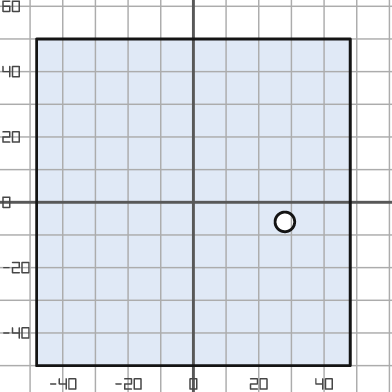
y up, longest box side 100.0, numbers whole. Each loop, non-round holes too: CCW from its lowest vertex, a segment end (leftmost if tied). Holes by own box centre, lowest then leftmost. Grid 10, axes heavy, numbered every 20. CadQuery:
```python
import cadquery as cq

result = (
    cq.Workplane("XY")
    .moveTo(-48.0, -50.0)
    .lineTo(48.0, -50.0)
    .lineTo(48.0, 50.0)
    .lineTo(-48.0, 50.0)
    .close()
    .moveTo(28.0, -6.0)
    .circle(3.0)
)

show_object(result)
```